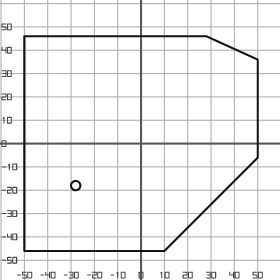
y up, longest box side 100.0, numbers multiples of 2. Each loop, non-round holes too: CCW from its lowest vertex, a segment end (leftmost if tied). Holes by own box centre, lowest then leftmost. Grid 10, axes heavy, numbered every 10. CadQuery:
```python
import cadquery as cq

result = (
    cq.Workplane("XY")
    .moveTo(-50.0, -46.0)
    .lineTo(10.0, -46.0)
    .lineTo(50.0, -6.0)
    .lineTo(50.0, 36.0)
    .lineTo(28.0, 46.0)
    .lineTo(-50.0, 46.0)
    .close()
    .moveTo(-28.0, -18.0)
    .circle(2.0)
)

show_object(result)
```